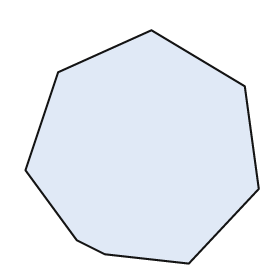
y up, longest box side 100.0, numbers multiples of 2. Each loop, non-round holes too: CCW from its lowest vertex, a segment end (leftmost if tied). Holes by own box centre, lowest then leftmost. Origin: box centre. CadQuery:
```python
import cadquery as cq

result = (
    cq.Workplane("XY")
    .moveTo(20.0, -50.0)
    .lineTo(50.0, -18.0)
    .lineTo(44.0, 26.0)
    .lineTo(4.0, 50.0)
    .lineTo(-36.0, 32.0)
    .lineTo(-50.0, -10.0)
    .lineTo(-28.0, -40.0)
    .lineTo(-16.0, -46.0)
    .close()
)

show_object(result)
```